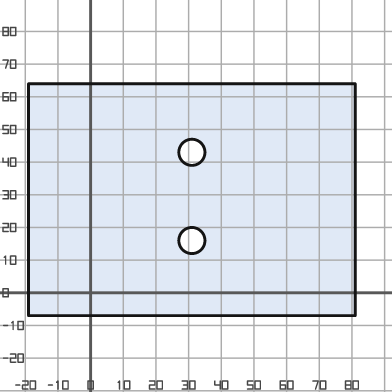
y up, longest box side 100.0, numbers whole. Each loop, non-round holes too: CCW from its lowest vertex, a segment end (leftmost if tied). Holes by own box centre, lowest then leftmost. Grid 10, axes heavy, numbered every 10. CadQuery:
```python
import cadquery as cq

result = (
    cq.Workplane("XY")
    .moveTo(-19.0, -7.0)
    .lineTo(81.0, -7.0)
    .lineTo(81.0, 64.0)
    .lineTo(-19.0, 64.0)
    .close()
    .moveTo(31.0, 16.0)
    .circle(4.0)
    .moveTo(31.0, 43.0)
    .circle(4.0)
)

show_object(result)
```